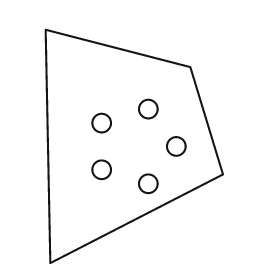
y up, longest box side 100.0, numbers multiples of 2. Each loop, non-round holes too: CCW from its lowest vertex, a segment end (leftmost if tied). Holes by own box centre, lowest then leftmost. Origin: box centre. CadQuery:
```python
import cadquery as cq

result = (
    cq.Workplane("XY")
    .moveTo(-36.0, -50.0)
    .lineTo(38.0, -12.0)
    .lineTo(24.0, 34.0)
    .lineTo(-38.0, 50.0)
    .close()
    .moveTo(6.0, -16.0)
    .circle(4.0)
    .moveTo(-14.0, -10.0)
    .circle(4.0)
    .moveTo(18.0, 0.0)
    .circle(4.0)
    .moveTo(-14.0, 10.0)
    .circle(4.0)
    .moveTo(6.0, 16.0)
    .circle(4.0)
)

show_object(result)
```